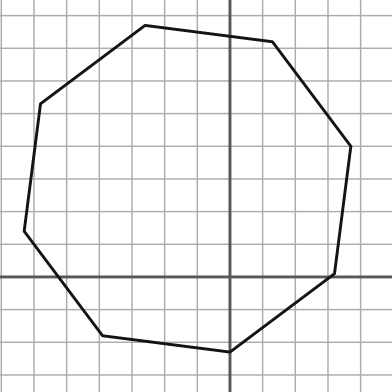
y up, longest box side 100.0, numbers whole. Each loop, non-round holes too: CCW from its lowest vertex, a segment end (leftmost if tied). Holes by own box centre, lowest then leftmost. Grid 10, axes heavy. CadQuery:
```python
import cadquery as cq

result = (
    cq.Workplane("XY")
    .moveTo(0.0, -23.0)
    .lineTo(32.0, 1.0)
    .lineTo(37.0, 40.0)
    .lineTo(13.0, 72.0)
    .lineTo(-26.0, 77.0)
    .lineTo(-58.0, 53.0)
    .lineTo(-63.0, 14.0)
    .lineTo(-39.0, -18.0)
    .close()
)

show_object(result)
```